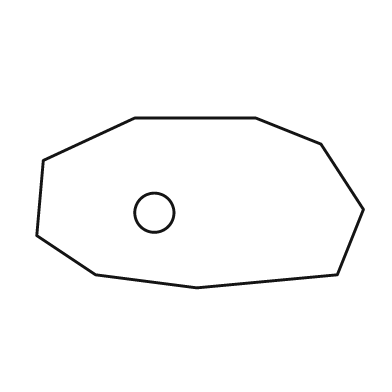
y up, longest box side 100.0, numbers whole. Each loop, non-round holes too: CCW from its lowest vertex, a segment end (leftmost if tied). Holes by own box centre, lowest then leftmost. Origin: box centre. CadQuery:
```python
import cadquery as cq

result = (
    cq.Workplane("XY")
    .moveTo(-1.0, -26.0)
    .lineTo(42.0, -22.0)
    .lineTo(50.0, -2.0)
    .lineTo(37.0, 18.0)
    .lineTo(17.0, 26.0)
    .lineTo(-20.0, 26.0)
    .lineTo(-48.0, 13.0)
    .lineTo(-50.0, -10.0)
    .lineTo(-32.0, -22.0)
    .close()
    .moveTo(-14.0, -3.0)
    .circle(6.0)
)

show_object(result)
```